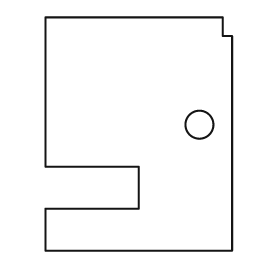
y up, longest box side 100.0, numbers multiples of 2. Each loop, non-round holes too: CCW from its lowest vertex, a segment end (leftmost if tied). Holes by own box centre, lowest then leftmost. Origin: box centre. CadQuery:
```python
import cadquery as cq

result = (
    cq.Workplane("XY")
    .moveTo(-40.0, -50.0)
    .lineTo(40.0, -50.0)
    .lineTo(40.0, 42.0)
    .lineTo(36.0, 42.0)
    .lineTo(36.0, 50.0)
    .lineTo(-40.0, 50.0)
    .lineTo(-40.0, -14.0)
    .lineTo(0.0, -14.0)
    .lineTo(0.0, -32.0)
    .lineTo(-40.0, -32.0)
    .close()
    .moveTo(26.0, 4.0)
    .circle(6.0)
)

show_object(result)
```